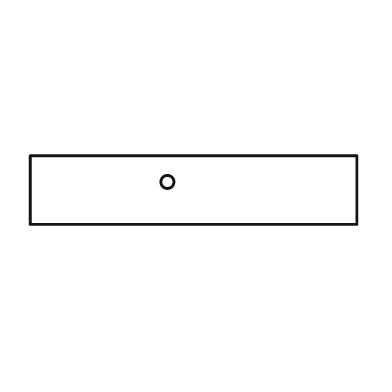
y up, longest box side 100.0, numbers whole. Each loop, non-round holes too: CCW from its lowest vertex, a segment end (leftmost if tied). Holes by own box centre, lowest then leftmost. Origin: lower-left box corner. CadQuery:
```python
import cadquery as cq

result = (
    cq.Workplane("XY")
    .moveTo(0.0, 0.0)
    .lineTo(100.0, 0.0)
    .lineTo(100.0, 21.0)
    .lineTo(0.0, 21.0)
    .close()
    .moveTo(42.0, 13.0)
    .circle(2.0)
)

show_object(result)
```